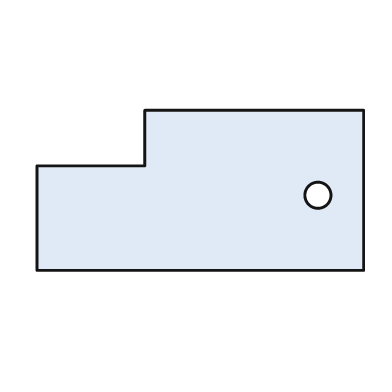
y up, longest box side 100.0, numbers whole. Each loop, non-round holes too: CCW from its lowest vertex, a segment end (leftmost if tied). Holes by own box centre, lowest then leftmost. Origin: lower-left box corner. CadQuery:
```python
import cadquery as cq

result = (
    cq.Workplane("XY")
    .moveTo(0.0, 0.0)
    .lineTo(100.0, 0.0)
    .lineTo(100.0, 49.0)
    .lineTo(33.0, 49.0)
    .lineTo(33.0, 32.0)
    .lineTo(0.0, 32.0)
    .close()
    .moveTo(86.0, 23.0)
    .circle(4.0)
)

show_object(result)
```